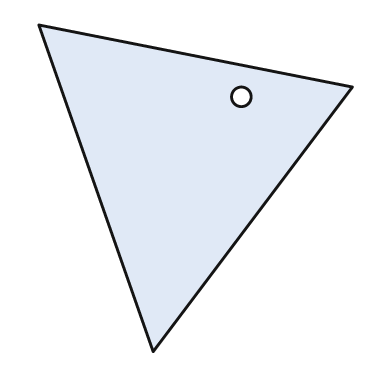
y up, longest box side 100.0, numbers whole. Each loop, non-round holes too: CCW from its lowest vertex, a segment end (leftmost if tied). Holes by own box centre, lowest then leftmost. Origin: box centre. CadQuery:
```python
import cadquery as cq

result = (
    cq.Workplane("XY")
    .moveTo(-13.0, -50.0)
    .lineTo(48.0, 31.0)
    .lineTo(-48.0, 50.0)
    .close()
    .moveTo(14.0, 28.0)
    .circle(3.0)
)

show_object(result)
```